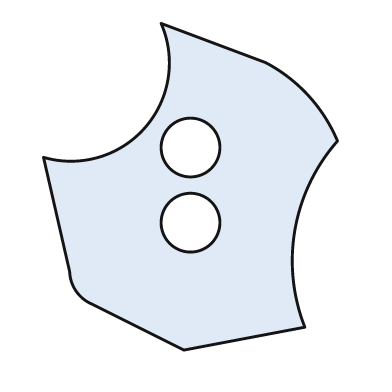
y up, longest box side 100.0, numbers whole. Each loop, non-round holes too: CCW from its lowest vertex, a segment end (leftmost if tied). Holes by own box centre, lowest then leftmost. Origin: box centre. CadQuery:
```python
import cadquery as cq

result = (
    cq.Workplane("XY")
    .moveTo(-2.0, -50.0)
    .lineTo(35.0, -43.0)
    .threePointArc((32.0, -13.0), (45.0, 14.0))
    .threePointArc((36.0, 28.0), (23.0, 38.0))
    .lineTo(-9.0, 50.0)
    .threePointArc((-14.0, 18.0), (-45.0, 9.0))
    .lineTo(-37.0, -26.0)
    .threePointArc((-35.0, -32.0), (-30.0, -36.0))
    .close()
    .moveTo(0.0, -11.0)
    .circle(9.0)
    .moveTo(0.0, 12.0)
    .circle(9.0)
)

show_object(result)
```